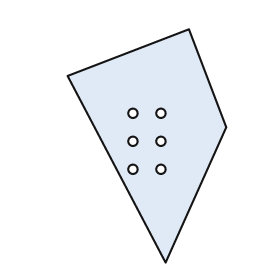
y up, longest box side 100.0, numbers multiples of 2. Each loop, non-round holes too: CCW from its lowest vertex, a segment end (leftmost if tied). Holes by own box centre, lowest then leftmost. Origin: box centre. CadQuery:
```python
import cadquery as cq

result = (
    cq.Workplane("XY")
    .moveTo(8.0, -50.0)
    .lineTo(34.0, 8.0)
    .lineTo(18.0, 50.0)
    .lineTo(-34.0, 30.0)
    .close()
    .moveTo(-6.0, -10.0)
    .circle(2.0)
    .moveTo(6.0, -10.0)
    .circle(2.0)
    .moveTo(-6.0, 2.0)
    .circle(2.0)
    .moveTo(6.0, 2.0)
    .circle(2.0)
    .moveTo(-6.0, 14.0)
    .circle(2.0)
    .moveTo(6.0, 14.0)
    .circle(2.0)
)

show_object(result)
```